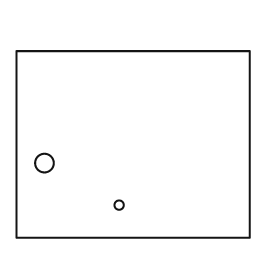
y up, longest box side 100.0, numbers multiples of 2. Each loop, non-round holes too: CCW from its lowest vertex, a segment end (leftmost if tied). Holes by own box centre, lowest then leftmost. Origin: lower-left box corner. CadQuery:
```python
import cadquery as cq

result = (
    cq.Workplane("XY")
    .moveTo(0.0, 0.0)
    .lineTo(100.0, 0.0)
    .lineTo(100.0, 80.0)
    .lineTo(0.0, 80.0)
    .close()
    .moveTo(44.0, 14.0)
    .circle(2.0)
    .moveTo(12.0, 32.0)
    .circle(4.0)
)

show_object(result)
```